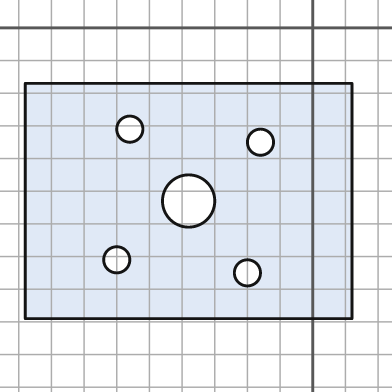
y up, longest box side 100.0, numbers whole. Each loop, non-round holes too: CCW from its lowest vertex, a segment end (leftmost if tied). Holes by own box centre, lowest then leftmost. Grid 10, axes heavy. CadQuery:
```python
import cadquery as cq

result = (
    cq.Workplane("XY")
    .moveTo(-88.0, -89.0)
    .lineTo(12.0, -89.0)
    .lineTo(12.0, -17.0)
    .lineTo(-88.0, -17.0)
    .close()
    .moveTo(-20.0, -75.0)
    .circle(4.0)
    .moveTo(-60.0, -71.0)
    .circle(4.0)
    .moveTo(-38.0, -53.0)
    .circle(8.0)
    .moveTo(-16.0, -35.0)
    .circle(4.0)
    .moveTo(-56.0, -31.0)
    .circle(4.0)
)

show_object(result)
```